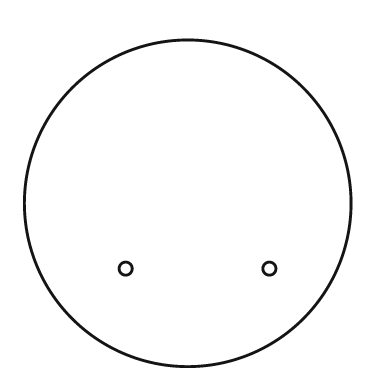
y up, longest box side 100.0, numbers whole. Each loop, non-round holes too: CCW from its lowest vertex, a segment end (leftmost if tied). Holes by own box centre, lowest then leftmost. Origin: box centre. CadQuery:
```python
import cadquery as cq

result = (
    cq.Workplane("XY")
    .moveTo(0.0, 0.0)
    .circle(50.0)
    .moveTo(-19.0, -20.0)
    .circle(2.0)
    .moveTo(25.0, -20.0)
    .circle(2.0)
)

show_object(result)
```